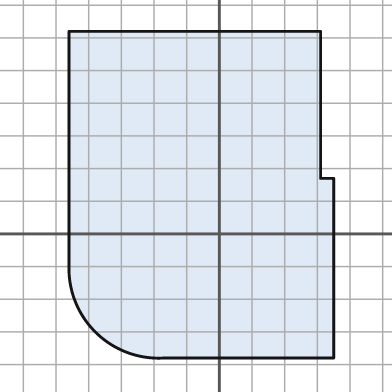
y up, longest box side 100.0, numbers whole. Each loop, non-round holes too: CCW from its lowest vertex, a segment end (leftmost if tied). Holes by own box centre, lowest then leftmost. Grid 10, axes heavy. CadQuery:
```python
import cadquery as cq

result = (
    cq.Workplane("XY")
    .moveTo(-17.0, -38.0)
    .lineTo(35.0, -38.0)
    .lineTo(35.0, 17.0)
    .lineTo(31.0, 17.0)
    .lineTo(31.0, 62.0)
    .lineTo(-46.0, 62.0)
    .lineTo(-46.0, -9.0)
    .threePointArc((-38.0, -30.0), (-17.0, -38.0))
    .close()
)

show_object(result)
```